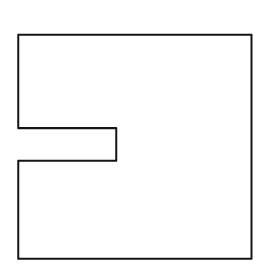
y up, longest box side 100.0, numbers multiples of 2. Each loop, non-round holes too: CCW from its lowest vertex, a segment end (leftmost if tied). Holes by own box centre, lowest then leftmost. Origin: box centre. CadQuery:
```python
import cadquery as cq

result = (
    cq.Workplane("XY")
    .moveTo(-50.0, -48.0)
    .lineTo(50.0, -48.0)
    .lineTo(50.0, 48.0)
    .lineTo(-50.0, 48.0)
    .lineTo(-50.0, 8.0)
    .lineTo(-8.0, 8.0)
    .lineTo(-8.0, -6.0)
    .lineTo(-50.0, -6.0)
    .close()
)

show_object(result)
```